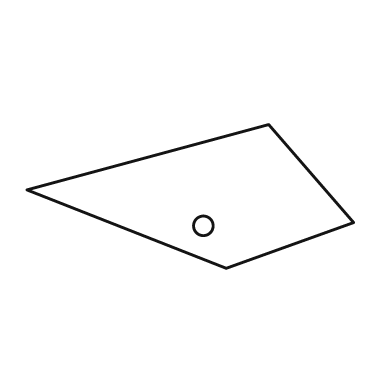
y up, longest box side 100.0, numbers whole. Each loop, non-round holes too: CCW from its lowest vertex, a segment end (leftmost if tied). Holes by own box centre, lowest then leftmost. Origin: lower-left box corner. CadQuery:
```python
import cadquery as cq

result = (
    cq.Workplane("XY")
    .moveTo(61.0, 0.0)
    .lineTo(100.0, 14.0)
    .lineTo(74.0, 44.0)
    .lineTo(0.0, 24.0)
    .close()
    .moveTo(54.0, 13.0)
    .circle(3.0)
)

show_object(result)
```